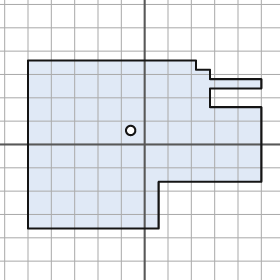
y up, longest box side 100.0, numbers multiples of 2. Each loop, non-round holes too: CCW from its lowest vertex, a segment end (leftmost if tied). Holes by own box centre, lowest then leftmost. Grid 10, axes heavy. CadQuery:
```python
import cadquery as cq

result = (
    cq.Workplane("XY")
    .moveTo(-50.0, -36.0)
    .lineTo(6.0, -36.0)
    .lineTo(6.0, -16.0)
    .lineTo(50.0, -16.0)
    .lineTo(50.0, 16.0)
    .lineTo(28.0, 16.0)
    .lineTo(28.0, 24.0)
    .lineTo(50.0, 24.0)
    .lineTo(50.0, 28.0)
    .lineTo(28.0, 28.0)
    .lineTo(28.0, 32.0)
    .lineTo(22.0, 32.0)
    .lineTo(22.0, 36.0)
    .lineTo(-50.0, 36.0)
    .close()
    .moveTo(-6.0, 6.0)
    .circle(2.0)
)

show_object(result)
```